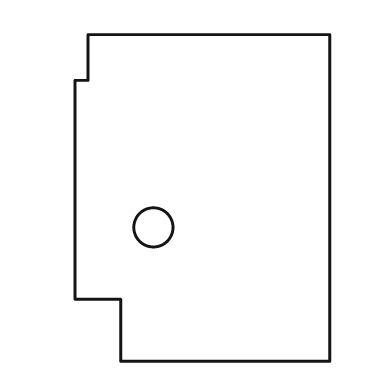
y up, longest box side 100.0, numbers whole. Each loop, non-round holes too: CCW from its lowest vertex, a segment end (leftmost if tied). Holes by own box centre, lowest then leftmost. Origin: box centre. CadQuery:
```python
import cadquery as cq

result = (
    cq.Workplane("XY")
    .moveTo(-25.0, -50.0)
    .lineTo(39.0, -50.0)
    .lineTo(39.0, 50.0)
    .lineTo(-35.0, 50.0)
    .lineTo(-35.0, 36.0)
    .lineTo(-39.0, 36.0)
    .lineTo(-39.0, -31.0)
    .lineTo(-25.0, -31.0)
    .close()
    .moveTo(-15.0, -9.0)
    .circle(6.0)
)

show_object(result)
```